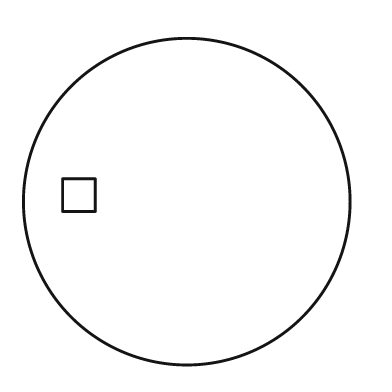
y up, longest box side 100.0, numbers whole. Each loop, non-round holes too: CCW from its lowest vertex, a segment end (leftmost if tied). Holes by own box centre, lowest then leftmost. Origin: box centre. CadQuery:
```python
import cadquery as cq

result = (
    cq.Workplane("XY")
    .moveTo(0.0, 0.0)
    .circle(50.0)
    .moveTo(-38.0, -3.0)
    .lineTo(-28.0, -3.0)
    .lineTo(-28.0, 7.0)
    .lineTo(-38.0, 7.0)
    .close()
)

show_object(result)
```